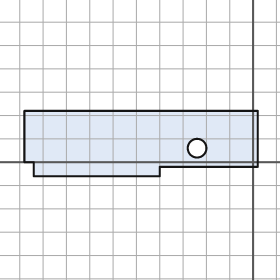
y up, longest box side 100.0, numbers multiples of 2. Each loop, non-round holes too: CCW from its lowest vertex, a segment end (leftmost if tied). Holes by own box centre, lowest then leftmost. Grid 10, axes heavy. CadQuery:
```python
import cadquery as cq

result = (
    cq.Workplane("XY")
    .moveTo(-94.0, -6.0)
    .lineTo(-40.0, -6.0)
    .lineTo(-40.0, -2.0)
    .lineTo(2.0, -2.0)
    .lineTo(2.0, 22.0)
    .lineTo(-98.0, 22.0)
    .lineTo(-98.0, 0.0)
    .lineTo(-94.0, 0.0)
    .close()
    .moveTo(-24.0, 6.0)
    .circle(4.0)
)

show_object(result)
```